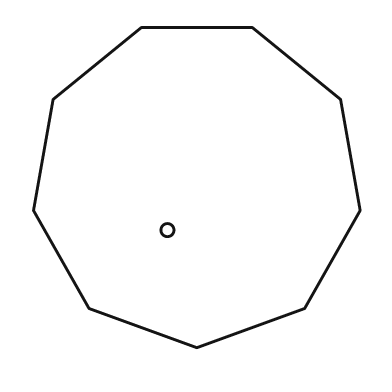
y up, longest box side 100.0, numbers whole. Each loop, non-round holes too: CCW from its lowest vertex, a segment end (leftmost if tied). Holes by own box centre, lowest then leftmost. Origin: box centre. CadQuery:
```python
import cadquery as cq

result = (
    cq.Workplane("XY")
    .moveTo(0.0, -49.0)
    .lineTo(33.0, -37.0)
    .lineTo(50.0, -7.0)
    .lineTo(44.0, 27.0)
    .lineTo(17.0, 49.0)
    .lineTo(-17.0, 49.0)
    .lineTo(-44.0, 27.0)
    .lineTo(-50.0, -7.0)
    .lineTo(-33.0, -37.0)
    .close()
    .moveTo(-9.0, -13.0)
    .circle(2.0)
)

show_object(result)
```